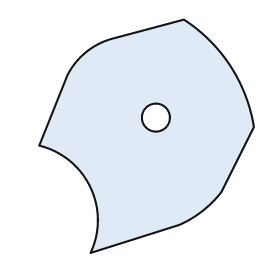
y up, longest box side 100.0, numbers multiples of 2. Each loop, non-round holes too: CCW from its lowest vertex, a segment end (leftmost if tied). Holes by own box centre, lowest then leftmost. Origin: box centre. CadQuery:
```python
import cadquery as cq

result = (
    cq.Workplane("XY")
    .moveTo(-24.0, -50.0)
    .lineTo(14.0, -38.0)
    .threePointArc((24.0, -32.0), (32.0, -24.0))
    .lineTo(46.0, 4.0)
    .threePointArc((36.0, 30.0), (16.0, 50.0))
    .lineTo(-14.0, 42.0)
    .threePointArc((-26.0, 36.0), (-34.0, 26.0))
    .lineTo(-46.0, -4.0)
    .threePointArc((-24.0, -22.0), (-24.0, -50.0))
    .close()
    .moveTo(4.0, 8.0)
    .circle(6.0)
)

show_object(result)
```